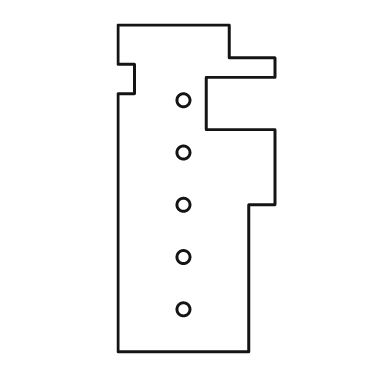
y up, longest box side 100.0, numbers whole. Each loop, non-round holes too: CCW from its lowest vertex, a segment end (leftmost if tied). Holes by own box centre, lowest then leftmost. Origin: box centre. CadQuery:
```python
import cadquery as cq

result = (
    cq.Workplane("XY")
    .moveTo(-24.0, -50.0)
    .lineTo(16.0, -50.0)
    .lineTo(16.0, -5.0)
    .lineTo(24.0, -5.0)
    .lineTo(24.0, 18.0)
    .lineTo(3.0, 18.0)
    .lineTo(3.0, 34.0)
    .lineTo(24.0, 34.0)
    .lineTo(24.0, 40.0)
    .lineTo(10.0, 40.0)
    .lineTo(10.0, 50.0)
    .lineTo(-24.0, 50.0)
    .lineTo(-24.0, 38.0)
    .lineTo(-19.0, 38.0)
    .lineTo(-19.0, 29.0)
    .lineTo(-24.0, 29.0)
    .close()
    .moveTo(-4.0, -37.0)
    .circle(2.0)
    .moveTo(-4.0, -21.0)
    .circle(2.0)
    .moveTo(-4.0, -5.0)
    .circle(2.0)
    .moveTo(-4.0, 11.0)
    .circle(2.0)
    .moveTo(-4.0, 27.0)
    .circle(2.0)
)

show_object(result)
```